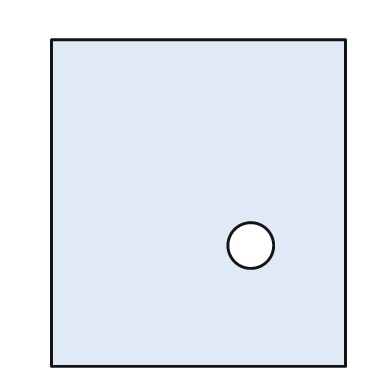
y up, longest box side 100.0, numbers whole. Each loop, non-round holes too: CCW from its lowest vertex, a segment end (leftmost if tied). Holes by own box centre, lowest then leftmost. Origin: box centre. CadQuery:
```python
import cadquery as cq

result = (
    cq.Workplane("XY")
    .moveTo(-45.0, -50.0)
    .lineTo(45.0, -50.0)
    .lineTo(45.0, 50.0)
    .lineTo(-45.0, 50.0)
    .close()
    .moveTo(16.0, -13.0)
    .circle(7.0)
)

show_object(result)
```